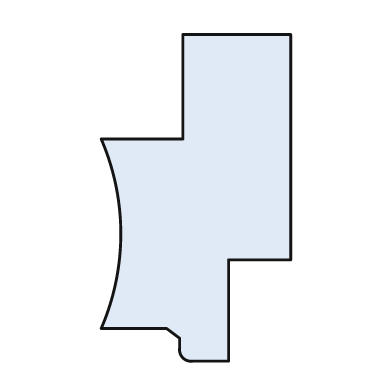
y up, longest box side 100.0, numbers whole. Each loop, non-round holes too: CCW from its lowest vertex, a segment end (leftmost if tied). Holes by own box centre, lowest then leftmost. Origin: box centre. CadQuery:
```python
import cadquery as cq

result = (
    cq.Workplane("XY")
    .moveTo(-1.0, -50.0)
    .lineTo(10.0, -50.0)
    .lineTo(10.0, -19.0)
    .lineTo(29.0, -19.0)
    .lineTo(29.0, 50.0)
    .lineTo(-4.0, 50.0)
    .lineTo(-4.0, 18.0)
    .lineTo(-29.0, 18.0)
    .threePointArc((-23.0, -11.0), (-29.0, -40.0))
    .lineTo(-9.0, -40.0)
    .lineTo(-5.0, -43.0)
    .lineTo(-5.0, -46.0)
    .threePointArc((-4.0, -49.0), (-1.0, -50.0))
    .close()
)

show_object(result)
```